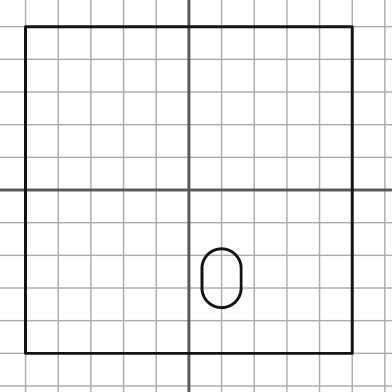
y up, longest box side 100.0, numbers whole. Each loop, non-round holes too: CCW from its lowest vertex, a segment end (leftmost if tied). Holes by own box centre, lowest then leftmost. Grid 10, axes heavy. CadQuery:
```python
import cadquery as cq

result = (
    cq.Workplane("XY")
    .moveTo(-50.0, -50.0)
    .lineTo(50.0, -50.0)
    .lineTo(50.0, 50.0)
    .lineTo(-50.0, 50.0)
    .close()
    .moveTo(4.0, -30.0)
    .threePointArc((10.0, -36.0), (16.0, -30.0))
    .lineTo(16.0, -24.0)
    .threePointArc((10.0, -18.0), (4.0, -24.0))
    .close()
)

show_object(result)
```